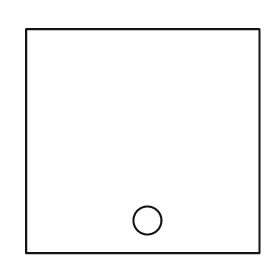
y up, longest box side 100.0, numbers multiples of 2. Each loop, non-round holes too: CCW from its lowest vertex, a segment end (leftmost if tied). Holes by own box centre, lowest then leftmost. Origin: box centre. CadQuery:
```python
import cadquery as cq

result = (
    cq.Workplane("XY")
    .moveTo(-50.0, -48.0)
    .lineTo(50.0, -48.0)
    .lineTo(50.0, 48.0)
    .lineTo(-50.0, 48.0)
    .close()
    .moveTo(2.0, -34.0)
    .circle(6.0)
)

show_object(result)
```